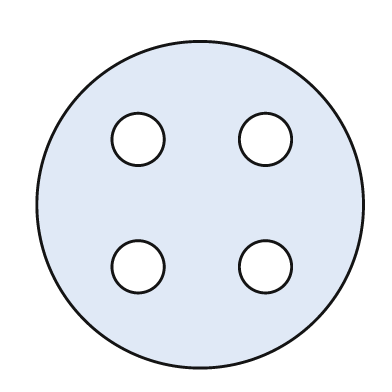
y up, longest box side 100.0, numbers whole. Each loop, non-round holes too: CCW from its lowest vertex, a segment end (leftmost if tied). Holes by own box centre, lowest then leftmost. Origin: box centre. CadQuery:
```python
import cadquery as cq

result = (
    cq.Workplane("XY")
    .moveTo(0.0, 0.0)
    .circle(50.0)
    .moveTo(-19.0, -19.0)
    .circle(8.0)
    .moveTo(20.0, -19.0)
    .circle(8.0)
    .moveTo(-19.0, 20.0)
    .circle(8.0)
    .moveTo(20.0, 20.0)
    .circle(8.0)
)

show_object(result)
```